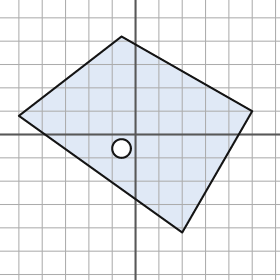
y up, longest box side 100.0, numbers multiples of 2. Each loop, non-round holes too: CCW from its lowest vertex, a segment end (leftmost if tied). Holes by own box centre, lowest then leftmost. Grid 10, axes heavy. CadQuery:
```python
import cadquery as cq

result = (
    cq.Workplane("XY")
    .moveTo(20.0, -42.0)
    .lineTo(50.0, 10.0)
    .lineTo(-6.0, 42.0)
    .lineTo(-50.0, 8.0)
    .close()
    .moveTo(-6.0, -6.0)
    .circle(4.0)
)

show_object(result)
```